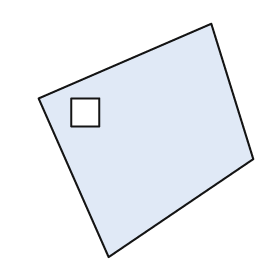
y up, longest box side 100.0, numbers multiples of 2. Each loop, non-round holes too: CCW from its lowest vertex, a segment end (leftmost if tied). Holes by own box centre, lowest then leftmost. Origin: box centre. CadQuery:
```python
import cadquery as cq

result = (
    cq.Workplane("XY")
    .moveTo(-16.0, -50.0)
    .lineTo(46.0, -8.0)
    .lineTo(28.0, 50.0)
    .lineTo(-46.0, 18.0)
    .close()
    .moveTo(-32.0, 6.0)
    .lineTo(-20.0, 6.0)
    .lineTo(-20.0, 18.0)
    .lineTo(-32.0, 18.0)
    .close()
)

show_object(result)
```